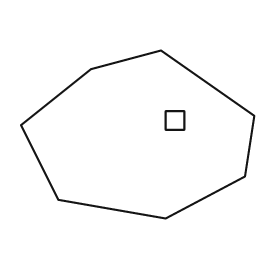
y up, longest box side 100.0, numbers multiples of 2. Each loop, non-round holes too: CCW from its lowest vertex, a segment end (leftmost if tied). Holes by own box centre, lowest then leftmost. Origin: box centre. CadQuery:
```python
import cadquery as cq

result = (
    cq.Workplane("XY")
    .moveTo(12.0, -36.0)
    .lineTo(46.0, -18.0)
    .lineTo(50.0, 8.0)
    .lineTo(10.0, 36.0)
    .lineTo(-20.0, 28.0)
    .lineTo(-50.0, 4.0)
    .lineTo(-34.0, -28.0)
    .close()
    .moveTo(12.0, 2.0)
    .lineTo(20.0, 2.0)
    .lineTo(20.0, 10.0)
    .lineTo(12.0, 10.0)
    .close()
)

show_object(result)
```